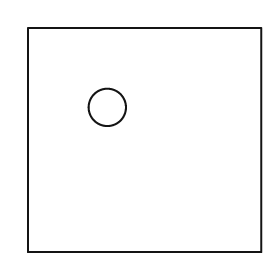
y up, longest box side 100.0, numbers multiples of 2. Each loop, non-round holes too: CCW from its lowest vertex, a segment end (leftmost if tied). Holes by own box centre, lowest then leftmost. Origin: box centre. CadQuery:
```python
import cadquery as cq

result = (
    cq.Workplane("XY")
    .moveTo(-50.0, -48.0)
    .lineTo(50.0, -48.0)
    .lineTo(50.0, 48.0)
    .lineTo(-50.0, 48.0)
    .close()
    .moveTo(-16.0, 14.0)
    .circle(8.0)
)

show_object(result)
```